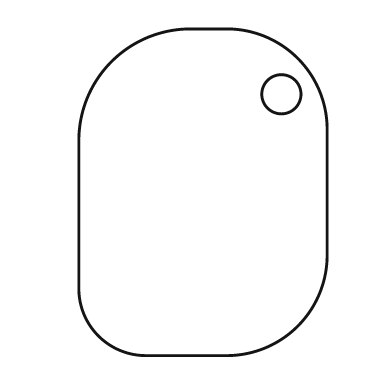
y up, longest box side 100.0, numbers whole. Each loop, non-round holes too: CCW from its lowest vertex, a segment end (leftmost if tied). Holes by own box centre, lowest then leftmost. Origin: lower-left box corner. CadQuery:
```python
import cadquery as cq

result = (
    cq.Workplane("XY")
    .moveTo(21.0, 0.0)
    .lineTo(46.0, 0.0)
    .threePointArc((67.0, 9.0), (76.0, 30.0))
    .lineTo(76.0, 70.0)
    .threePointArc((67.0, 91.0), (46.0, 100.0))
    .lineTo(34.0, 100.0)
    .threePointArc((10.0, 90.0), (0.0, 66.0))
    .lineTo(0.0, 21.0)
    .threePointArc((6.0, 6.0), (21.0, 0.0))
    .close()
    .moveTo(62.0, 80.0)
    .circle(6.0)
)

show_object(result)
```